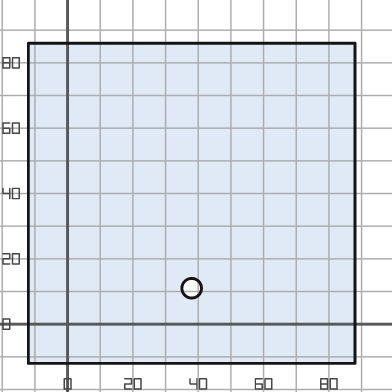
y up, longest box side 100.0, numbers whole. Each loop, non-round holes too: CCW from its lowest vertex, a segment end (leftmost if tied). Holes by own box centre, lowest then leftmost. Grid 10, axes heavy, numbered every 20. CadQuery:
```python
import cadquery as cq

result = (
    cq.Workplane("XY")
    .moveTo(-12.0, -12.0)
    .lineTo(88.0, -12.0)
    .lineTo(88.0, 86.0)
    .lineTo(-12.0, 86.0)
    .close()
    .moveTo(38.0, 11.0)
    .circle(3.0)
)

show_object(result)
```